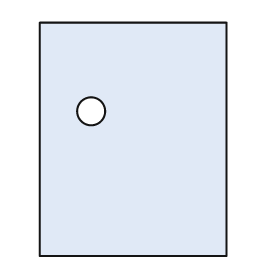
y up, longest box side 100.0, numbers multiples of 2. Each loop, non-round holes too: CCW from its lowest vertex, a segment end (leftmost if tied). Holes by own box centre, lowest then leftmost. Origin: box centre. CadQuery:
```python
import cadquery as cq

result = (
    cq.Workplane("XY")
    .moveTo(-40.0, -50.0)
    .lineTo(40.0, -50.0)
    .lineTo(40.0, 50.0)
    .lineTo(-40.0, 50.0)
    .close()
    .moveTo(-18.0, 12.0)
    .circle(6.0)
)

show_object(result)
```